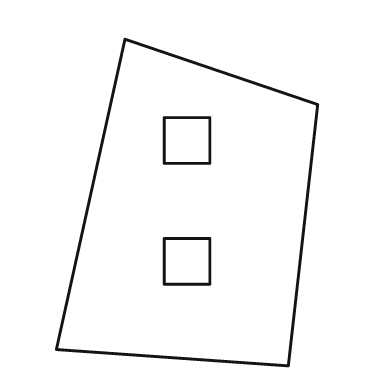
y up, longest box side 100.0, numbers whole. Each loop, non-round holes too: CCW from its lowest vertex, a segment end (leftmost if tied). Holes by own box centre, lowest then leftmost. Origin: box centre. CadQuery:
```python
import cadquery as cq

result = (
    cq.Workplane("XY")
    .moveTo(31.0, -50.0)
    .lineTo(40.0, 30.0)
    .lineTo(-19.0, 50.0)
    .lineTo(-40.0, -45.0)
    .close()
    .moveTo(-7.0, -25.0)
    .lineTo(7.0, -25.0)
    .lineTo(7.0, -11.0)
    .lineTo(-7.0, -11.0)
    .close()
    .moveTo(-7.0, 12.0)
    .lineTo(7.0, 12.0)
    .lineTo(7.0, 26.0)
    .lineTo(-7.0, 26.0)
    .close()
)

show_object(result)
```